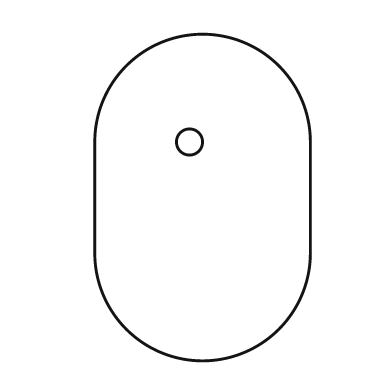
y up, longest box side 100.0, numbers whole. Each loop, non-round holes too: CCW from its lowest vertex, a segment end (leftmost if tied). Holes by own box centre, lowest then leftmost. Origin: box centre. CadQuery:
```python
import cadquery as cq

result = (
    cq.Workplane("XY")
    .moveTo(-33.0, -17.0)
    .threePointArc((0.0, -50.0), (33.0, -17.0))
    .lineTo(33.0, 17.0)
    .threePointArc((0.0, 50.0), (-33.0, 17.0))
    .close()
    .moveTo(-4.0, 17.0)
    .circle(4.0)
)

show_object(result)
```